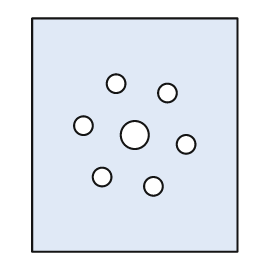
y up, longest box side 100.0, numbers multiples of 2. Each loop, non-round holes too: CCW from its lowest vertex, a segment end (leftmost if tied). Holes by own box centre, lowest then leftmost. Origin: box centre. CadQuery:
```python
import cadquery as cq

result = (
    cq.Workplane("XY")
    .moveTo(-44.0, -50.0)
    .lineTo(44.0, -50.0)
    .lineTo(44.0, 50.0)
    .lineTo(-44.0, 50.0)
    .close()
    .moveTo(8.0, -22.0)
    .circle(4.0)
    .moveTo(-14.0, -18.0)
    .circle(4.0)
    .moveTo(22.0, -4.0)
    .circle(4.0)
    .moveTo(0.0, 0.0)
    .circle(6.0)
    .moveTo(-22.0, 4.0)
    .circle(4.0)
    .moveTo(14.0, 18.0)
    .circle(4.0)
    .moveTo(-8.0, 22.0)
    .circle(4.0)
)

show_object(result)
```